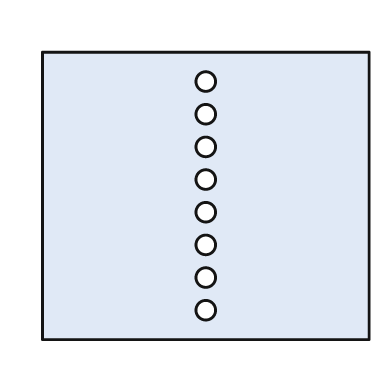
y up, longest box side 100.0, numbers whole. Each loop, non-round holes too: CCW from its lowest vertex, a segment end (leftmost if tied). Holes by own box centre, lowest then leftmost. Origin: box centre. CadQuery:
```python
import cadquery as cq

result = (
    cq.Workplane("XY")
    .moveTo(-50.0, -44.0)
    .lineTo(50.0, -44.0)
    .lineTo(50.0, 44.0)
    .lineTo(-50.0, 44.0)
    .close()
    .moveTo(0.0, -35.0)
    .circle(3.0)
    .moveTo(0.0, -25.0)
    .circle(3.0)
    .moveTo(0.0, -15.0)
    .circle(3.0)
    .moveTo(0.0, -5.0)
    .circle(3.0)
    .moveTo(0.0, 5.0)
    .circle(3.0)
    .moveTo(0.0, 15.0)
    .circle(3.0)
    .moveTo(0.0, 25.0)
    .circle(3.0)
    .moveTo(0.0, 35.0)
    .circle(3.0)
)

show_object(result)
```